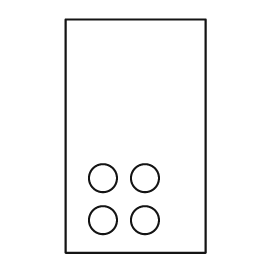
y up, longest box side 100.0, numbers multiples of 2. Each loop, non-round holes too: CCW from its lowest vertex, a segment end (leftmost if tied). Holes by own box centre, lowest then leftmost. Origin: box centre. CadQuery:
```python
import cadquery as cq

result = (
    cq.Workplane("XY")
    .moveTo(-30.0, -50.0)
    .lineTo(30.0, -50.0)
    .lineTo(30.0, 50.0)
    .lineTo(-30.0, 50.0)
    .close()
    .moveTo(-14.0, -36.0)
    .circle(6.0)
    .moveTo(4.0, -36.0)
    .circle(6.0)
    .moveTo(-14.0, -18.0)
    .circle(6.0)
    .moveTo(4.0, -18.0)
    .circle(6.0)
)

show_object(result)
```